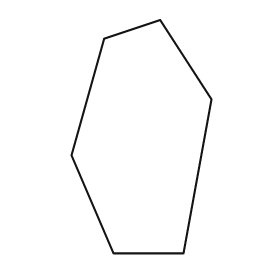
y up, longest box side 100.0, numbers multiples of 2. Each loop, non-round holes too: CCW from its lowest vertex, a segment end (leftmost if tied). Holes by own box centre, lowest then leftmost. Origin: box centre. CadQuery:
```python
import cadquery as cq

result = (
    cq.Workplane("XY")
    .moveTo(-12.0, -50.0)
    .lineTo(18.0, -50.0)
    .lineTo(30.0, 16.0)
    .lineTo(8.0, 50.0)
    .lineTo(-16.0, 42.0)
    .lineTo(-30.0, -8.0)
    .close()
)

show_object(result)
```